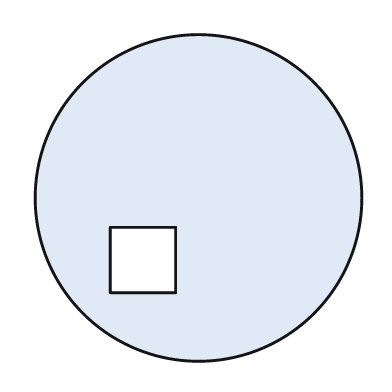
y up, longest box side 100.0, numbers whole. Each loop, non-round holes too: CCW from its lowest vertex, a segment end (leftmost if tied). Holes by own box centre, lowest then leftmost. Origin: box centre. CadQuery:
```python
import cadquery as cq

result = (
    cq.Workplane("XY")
    .moveTo(0.0, 0.0)
    .circle(50.0)
    .moveTo(-27.0, -29.0)
    .lineTo(-7.0, -29.0)
    .lineTo(-7.0, -9.0)
    .lineTo(-27.0, -9.0)
    .close()
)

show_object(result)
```